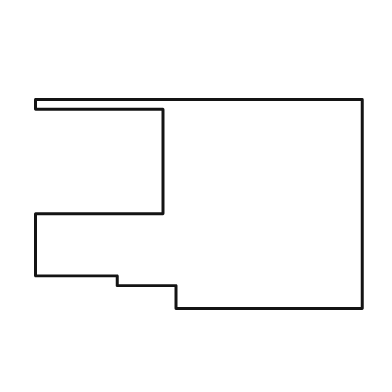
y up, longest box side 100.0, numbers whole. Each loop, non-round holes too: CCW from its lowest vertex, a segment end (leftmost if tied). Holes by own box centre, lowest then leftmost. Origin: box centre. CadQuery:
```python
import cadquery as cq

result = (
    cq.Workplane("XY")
    .moveTo(-7.0, -32.0)
    .lineTo(50.0, -32.0)
    .lineTo(50.0, 32.0)
    .lineTo(-50.0, 32.0)
    .lineTo(-50.0, 29.0)
    .lineTo(-11.0, 29.0)
    .lineTo(-11.0, -3.0)
    .lineTo(-50.0, -3.0)
    .lineTo(-50.0, -22.0)
    .lineTo(-25.0, -22.0)
    .lineTo(-25.0, -25.0)
    .lineTo(-7.0, -25.0)
    .close()
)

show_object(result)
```